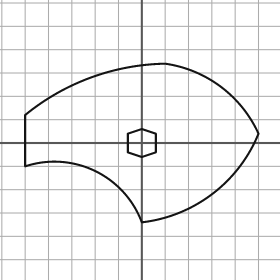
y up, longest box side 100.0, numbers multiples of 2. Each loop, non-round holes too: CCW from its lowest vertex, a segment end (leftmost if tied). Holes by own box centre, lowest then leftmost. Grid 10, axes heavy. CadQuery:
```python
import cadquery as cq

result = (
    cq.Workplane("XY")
    .moveTo(0.0, -34.0)
    .threePointArc((30.0, -22.0), (50.0, 4.0))
    .threePointArc((34.0, 24.0), (10.0, 34.0))
    .threePointArc((-22.0, 28.0), (-50.0, 12.0))
    .lineTo(-50.0, -10.0)
    .threePointArc((-20.0, -12.0), (0.0, -34.0))
    .close()
    .moveTo(0.0, -6.0)
    .lineTo(6.0, -4.0)
    .lineTo(6.0, 4.0)
    .lineTo(0.0, 6.0)
    .lineTo(-6.0, 4.0)
    .lineTo(-6.0, -4.0)
    .close()
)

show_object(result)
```